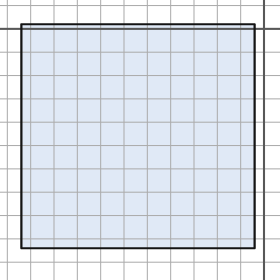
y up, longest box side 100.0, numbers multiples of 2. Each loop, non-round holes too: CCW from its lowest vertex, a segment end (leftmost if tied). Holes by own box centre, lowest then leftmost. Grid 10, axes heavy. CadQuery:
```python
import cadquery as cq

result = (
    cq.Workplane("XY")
    .moveTo(-104.0, -94.0)
    .lineTo(-4.0, -94.0)
    .lineTo(-4.0, 2.0)
    .lineTo(-104.0, 2.0)
    .close()
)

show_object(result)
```